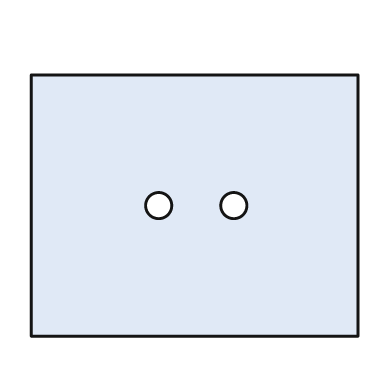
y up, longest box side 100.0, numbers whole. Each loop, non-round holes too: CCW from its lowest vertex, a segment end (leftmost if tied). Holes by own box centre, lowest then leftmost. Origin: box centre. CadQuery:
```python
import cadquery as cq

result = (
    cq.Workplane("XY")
    .moveTo(-50.0, -40.0)
    .lineTo(50.0, -40.0)
    .lineTo(50.0, 40.0)
    .lineTo(-50.0, 40.0)
    .close()
    .moveTo(-11.0, 0.0)
    .circle(4.0)
    .moveTo(12.0, 0.0)
    .circle(4.0)
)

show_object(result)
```